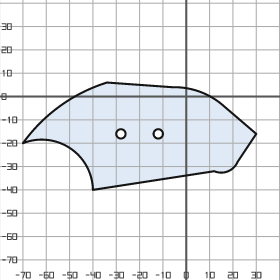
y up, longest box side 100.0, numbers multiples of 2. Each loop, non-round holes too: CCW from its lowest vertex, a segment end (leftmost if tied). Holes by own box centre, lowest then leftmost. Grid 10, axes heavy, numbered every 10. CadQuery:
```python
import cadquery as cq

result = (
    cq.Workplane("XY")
    .moveTo(-40.0, -40.0)
    .lineTo(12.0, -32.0)
    .threePointArc((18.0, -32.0), (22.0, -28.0))
    .lineTo(30.0, -16.0)
    .lineTo(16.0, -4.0)
    .threePointArc((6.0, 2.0), (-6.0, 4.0))
    .lineTo(-34.0, 6.0)
    .threePointArc((-54.0, -4.0), (-70.0, -20.0))
    .threePointArc((-50.0, -22.0), (-40.0, -40.0))
    .close()
    .moveTo(-28.0, -16.0)
    .circle(2.0)
    .moveTo(-12.0, -16.0)
    .circle(2.0)
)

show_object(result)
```